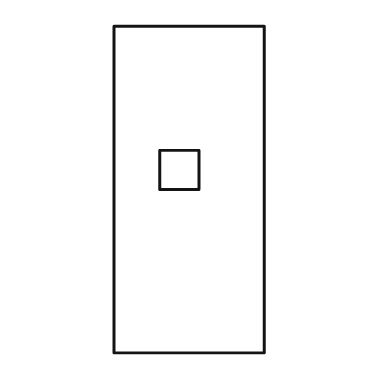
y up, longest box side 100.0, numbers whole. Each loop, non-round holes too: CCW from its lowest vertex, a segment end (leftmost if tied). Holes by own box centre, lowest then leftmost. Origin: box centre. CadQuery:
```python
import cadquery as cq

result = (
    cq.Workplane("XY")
    .moveTo(-23.0, -50.0)
    .lineTo(23.0, -50.0)
    .lineTo(23.0, 50.0)
    .lineTo(-23.0, 50.0)
    .close()
    .moveTo(-9.0, 0.0)
    .lineTo(3.0, 0.0)
    .lineTo(3.0, 12.0)
    .lineTo(-9.0, 12.0)
    .close()
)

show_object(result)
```